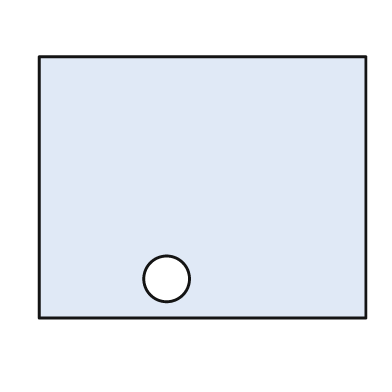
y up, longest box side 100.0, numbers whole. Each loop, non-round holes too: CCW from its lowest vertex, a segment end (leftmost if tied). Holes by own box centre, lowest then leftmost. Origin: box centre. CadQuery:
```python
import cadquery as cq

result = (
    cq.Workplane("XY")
    .moveTo(-50.0, -40.0)
    .lineTo(50.0, -40.0)
    .lineTo(50.0, 40.0)
    .lineTo(-50.0, 40.0)
    .close()
    .moveTo(-11.0, -28.0)
    .circle(7.0)
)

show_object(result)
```